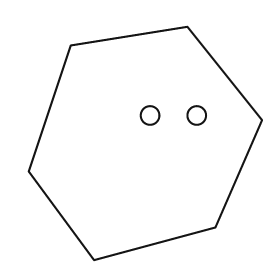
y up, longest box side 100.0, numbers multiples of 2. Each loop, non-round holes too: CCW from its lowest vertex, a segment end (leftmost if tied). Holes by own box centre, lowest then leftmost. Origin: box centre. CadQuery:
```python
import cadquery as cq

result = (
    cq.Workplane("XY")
    .moveTo(-22.0, -50.0)
    .lineTo(30.0, -36.0)
    .lineTo(50.0, 10.0)
    .lineTo(18.0, 50.0)
    .lineTo(-32.0, 42.0)
    .lineTo(-50.0, -12.0)
    .close()
    .moveTo(2.0, 12.0)
    .circle(4.0)
    .moveTo(22.0, 12.0)
    .circle(4.0)
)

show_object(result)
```